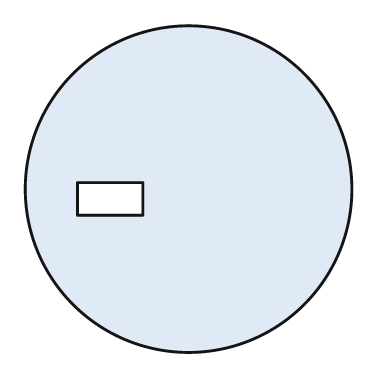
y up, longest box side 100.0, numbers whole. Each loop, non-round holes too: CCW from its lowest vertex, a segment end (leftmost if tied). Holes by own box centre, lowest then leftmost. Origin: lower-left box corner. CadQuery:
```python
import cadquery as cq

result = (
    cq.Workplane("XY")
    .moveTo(50.0, 50.0)
    .circle(50.0)
    .moveTo(16.0, 42.0)
    .lineTo(36.0, 42.0)
    .lineTo(36.0, 52.0)
    .lineTo(16.0, 52.0)
    .close()
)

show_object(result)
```